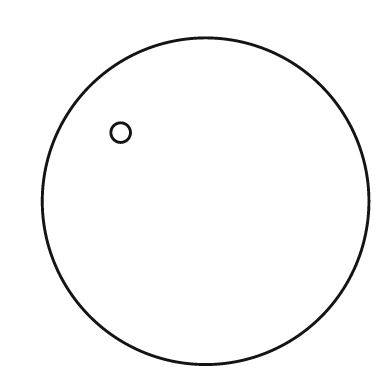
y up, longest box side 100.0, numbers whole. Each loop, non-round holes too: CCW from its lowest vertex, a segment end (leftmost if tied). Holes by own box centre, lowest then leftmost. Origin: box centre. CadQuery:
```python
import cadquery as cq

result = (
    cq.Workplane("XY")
    .moveTo(0.0, 0.0)
    .circle(50.0)
    .moveTo(-26.0, 21.0)
    .circle(3.0)
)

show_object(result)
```